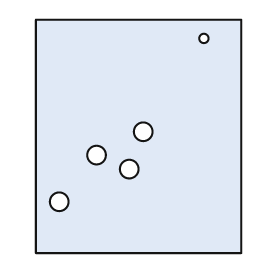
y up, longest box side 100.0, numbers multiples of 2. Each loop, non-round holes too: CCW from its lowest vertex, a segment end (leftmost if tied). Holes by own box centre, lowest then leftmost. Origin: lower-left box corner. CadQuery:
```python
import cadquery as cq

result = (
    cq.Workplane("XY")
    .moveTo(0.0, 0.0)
    .lineTo(88.0, 0.0)
    .lineTo(88.0, 100.0)
    .lineTo(0.0, 100.0)
    .close()
    .moveTo(10.0, 22.0)
    .circle(4.0)
    .moveTo(40.0, 36.0)
    .circle(4.0)
    .moveTo(26.0, 42.0)
    .circle(4.0)
    .moveTo(46.0, 52.0)
    .circle(4.0)
    .moveTo(72.0, 92.0)
    .circle(2.0)
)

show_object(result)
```